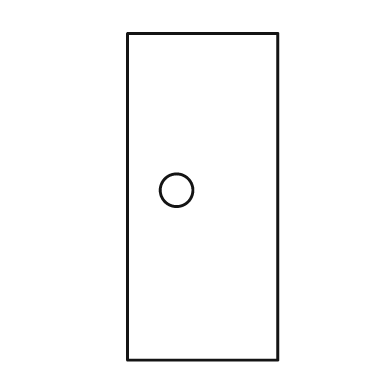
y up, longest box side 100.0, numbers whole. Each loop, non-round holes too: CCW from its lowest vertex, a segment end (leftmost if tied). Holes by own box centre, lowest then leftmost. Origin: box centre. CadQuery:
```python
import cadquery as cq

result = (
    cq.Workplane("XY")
    .moveTo(-23.0, -50.0)
    .lineTo(23.0, -50.0)
    .lineTo(23.0, 50.0)
    .lineTo(-23.0, 50.0)
    .close()
    .moveTo(-8.0, 2.0)
    .circle(5.0)
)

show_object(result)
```